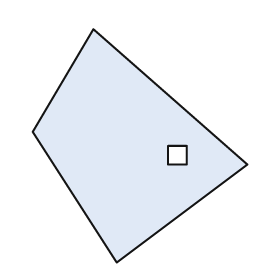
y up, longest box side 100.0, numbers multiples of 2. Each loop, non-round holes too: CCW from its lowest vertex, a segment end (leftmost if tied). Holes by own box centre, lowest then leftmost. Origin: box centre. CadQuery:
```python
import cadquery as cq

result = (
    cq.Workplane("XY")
    .moveTo(-10.0, -50.0)
    .lineTo(46.0, -8.0)
    .lineTo(-20.0, 50.0)
    .lineTo(-46.0, 6.0)
    .close()
    .moveTo(12.0, -8.0)
    .lineTo(20.0, -8.0)
    .lineTo(20.0, 0.0)
    .lineTo(12.0, 0.0)
    .close()
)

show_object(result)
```